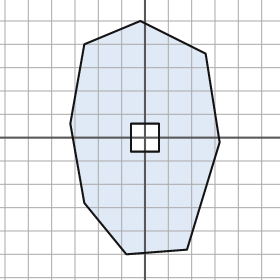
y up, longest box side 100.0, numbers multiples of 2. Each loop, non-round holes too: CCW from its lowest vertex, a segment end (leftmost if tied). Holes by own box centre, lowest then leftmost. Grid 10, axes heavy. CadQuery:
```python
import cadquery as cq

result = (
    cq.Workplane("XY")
    .moveTo(-8.0, -50.0)
    .lineTo(18.0, -48.0)
    .lineTo(32.0, -2.0)
    .lineTo(26.0, 36.0)
    .lineTo(-2.0, 50.0)
    .lineTo(-26.0, 40.0)
    .lineTo(-32.0, 6.0)
    .lineTo(-26.0, -28.0)
    .close()
    .moveTo(-6.0, -6.0)
    .lineTo(6.0, -6.0)
    .lineTo(6.0, 6.0)
    .lineTo(-6.0, 6.0)
    .close()
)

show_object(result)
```